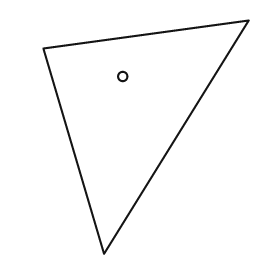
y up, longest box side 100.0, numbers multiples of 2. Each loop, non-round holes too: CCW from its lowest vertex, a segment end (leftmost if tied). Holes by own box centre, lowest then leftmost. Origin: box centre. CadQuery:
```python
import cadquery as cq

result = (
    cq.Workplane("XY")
    .moveTo(-18.0, -50.0)
    .lineTo(44.0, 50.0)
    .lineTo(-44.0, 38.0)
    .close()
    .moveTo(-10.0, 26.0)
    .circle(2.0)
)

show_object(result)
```